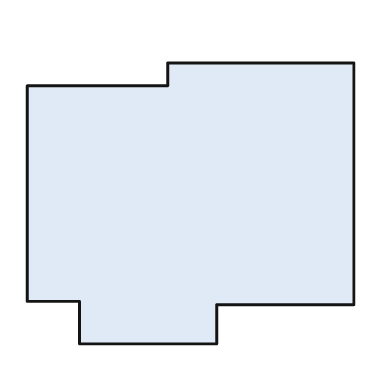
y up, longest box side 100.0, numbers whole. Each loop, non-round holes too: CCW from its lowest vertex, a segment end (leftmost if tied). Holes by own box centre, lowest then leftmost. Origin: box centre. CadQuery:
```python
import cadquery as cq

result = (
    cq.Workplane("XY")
    .moveTo(-34.0, -43.0)
    .lineTo(8.0, -43.0)
    .lineTo(8.0, -31.0)
    .lineTo(50.0, -31.0)
    .lineTo(50.0, 43.0)
    .lineTo(-7.0, 43.0)
    .lineTo(-7.0, 36.0)
    .lineTo(-50.0, 36.0)
    .lineTo(-50.0, -30.0)
    .lineTo(-34.0, -30.0)
    .close()
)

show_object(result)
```